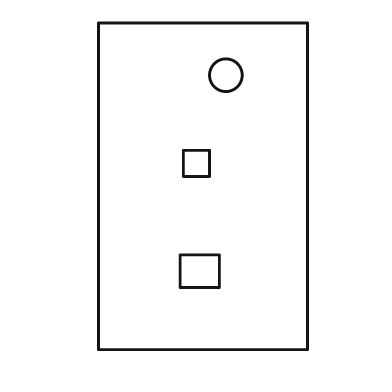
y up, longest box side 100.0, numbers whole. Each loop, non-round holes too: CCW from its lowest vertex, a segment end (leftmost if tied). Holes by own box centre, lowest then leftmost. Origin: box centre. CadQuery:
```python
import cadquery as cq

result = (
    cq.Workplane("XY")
    .moveTo(-32.0, -50.0)
    .lineTo(32.0, -50.0)
    .lineTo(32.0, 50.0)
    .lineTo(-32.0, 50.0)
    .close()
    .moveTo(-7.0, -31.0)
    .lineTo(5.0, -31.0)
    .lineTo(5.0, -21.0)
    .lineTo(-7.0, -21.0)
    .close()
    .moveTo(-6.0, 3.0)
    .lineTo(2.0, 3.0)
    .lineTo(2.0, 11.0)
    .lineTo(-6.0, 11.0)
    .close()
    .moveTo(7.0, 34.0)
    .circle(5.0)
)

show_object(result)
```